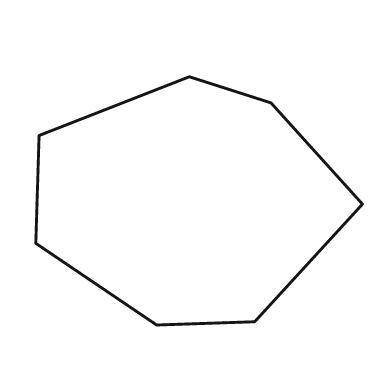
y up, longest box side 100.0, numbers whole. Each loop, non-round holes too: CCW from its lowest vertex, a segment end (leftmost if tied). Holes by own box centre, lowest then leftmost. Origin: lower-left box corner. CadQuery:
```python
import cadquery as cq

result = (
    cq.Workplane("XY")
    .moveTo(37.0, 0.0)
    .lineTo(67.0, 1.0)
    .lineTo(100.0, 37.0)
    .lineTo(72.0, 68.0)
    .lineTo(47.0, 76.0)
    .lineTo(1.0, 58.0)
    .lineTo(0.0, 25.0)
    .close()
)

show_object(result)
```